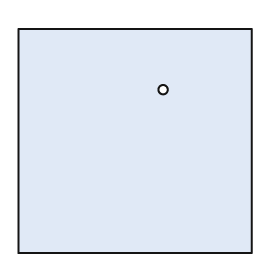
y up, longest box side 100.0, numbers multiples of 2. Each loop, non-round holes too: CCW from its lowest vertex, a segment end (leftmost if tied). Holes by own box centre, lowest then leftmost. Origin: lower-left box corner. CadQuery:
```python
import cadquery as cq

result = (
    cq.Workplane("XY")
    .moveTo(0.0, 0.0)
    .lineTo(100.0, 0.0)
    .lineTo(100.0, 96.0)
    .lineTo(0.0, 96.0)
    .close()
    .moveTo(62.0, 70.0)
    .circle(2.0)
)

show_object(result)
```